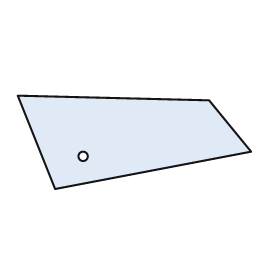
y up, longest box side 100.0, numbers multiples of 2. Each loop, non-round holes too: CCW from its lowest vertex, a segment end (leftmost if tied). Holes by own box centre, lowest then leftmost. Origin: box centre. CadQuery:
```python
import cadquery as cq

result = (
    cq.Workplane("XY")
    .moveTo(-34.0, -20.0)
    .lineTo(50.0, -4.0)
    .lineTo(32.0, 18.0)
    .lineTo(-50.0, 20.0)
    .close()
    .moveTo(-22.0, -6.0)
    .circle(2.0)
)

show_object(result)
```